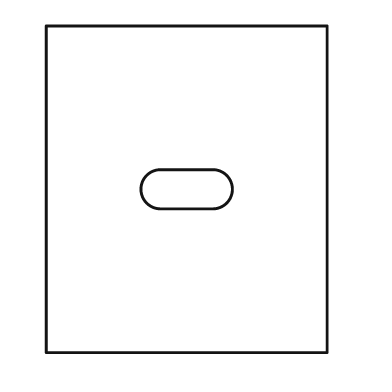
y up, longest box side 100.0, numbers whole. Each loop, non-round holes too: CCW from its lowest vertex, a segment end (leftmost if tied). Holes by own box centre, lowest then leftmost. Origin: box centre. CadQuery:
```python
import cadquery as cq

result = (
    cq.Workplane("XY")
    .moveTo(-43.0, -50.0)
    .lineTo(43.0, -50.0)
    .lineTo(43.0, 50.0)
    .lineTo(-43.0, 50.0)
    .close()
    .moveTo(-8.0, -6.0)
    .lineTo(8.0, -6.0)
    .threePointArc((14.0, 0.0), (8.0, 6.0))
    .lineTo(-8.0, 6.0)
    .threePointArc((-14.0, 0.0), (-8.0, -6.0))
    .close()
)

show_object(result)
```